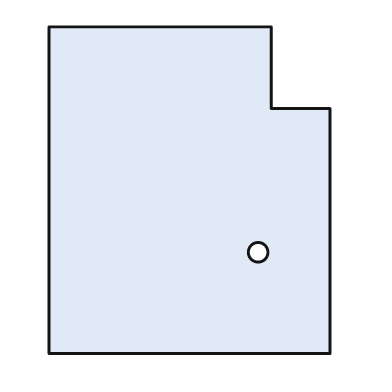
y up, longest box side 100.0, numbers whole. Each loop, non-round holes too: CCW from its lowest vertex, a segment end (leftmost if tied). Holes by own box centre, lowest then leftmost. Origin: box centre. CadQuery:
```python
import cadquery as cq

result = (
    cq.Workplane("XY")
    .moveTo(-43.0, -50.0)
    .lineTo(43.0, -50.0)
    .lineTo(43.0, 25.0)
    .lineTo(25.0, 25.0)
    .lineTo(25.0, 50.0)
    .lineTo(-43.0, 50.0)
    .close()
    .moveTo(21.0, -19.0)
    .circle(3.0)
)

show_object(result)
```